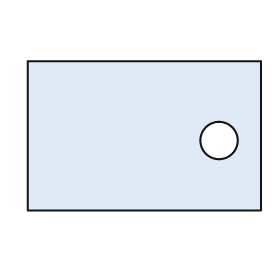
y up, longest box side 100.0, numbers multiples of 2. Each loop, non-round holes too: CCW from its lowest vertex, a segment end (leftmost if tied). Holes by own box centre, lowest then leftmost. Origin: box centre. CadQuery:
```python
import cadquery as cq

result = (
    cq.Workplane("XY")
    .moveTo(-50.0, -32.0)
    .lineTo(50.0, -32.0)
    .lineTo(50.0, 32.0)
    .lineTo(-50.0, 32.0)
    .close()
    .moveTo(32.0, -2.0)
    .circle(8.0)
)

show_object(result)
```